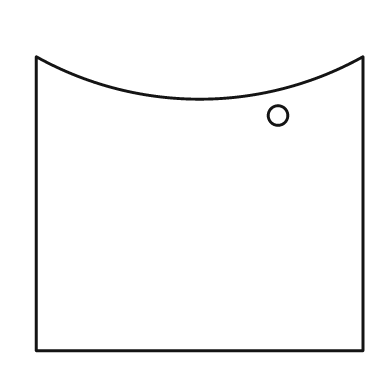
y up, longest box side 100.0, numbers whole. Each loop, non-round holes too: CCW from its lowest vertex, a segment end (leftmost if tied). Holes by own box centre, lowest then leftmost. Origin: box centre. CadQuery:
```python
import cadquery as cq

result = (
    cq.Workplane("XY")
    .moveTo(-50.0, -45.0)
    .lineTo(50.0, -45.0)
    .lineTo(50.0, 45.0)
    .threePointArc((0.0, 32.0), (-50.0, 45.0))
    .close()
    .moveTo(24.0, 27.0)
    .circle(3.0)
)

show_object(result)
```